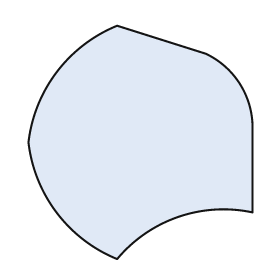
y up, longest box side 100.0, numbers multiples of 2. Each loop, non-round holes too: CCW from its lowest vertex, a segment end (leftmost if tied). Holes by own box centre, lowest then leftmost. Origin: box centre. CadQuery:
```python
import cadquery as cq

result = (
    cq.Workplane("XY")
    .moveTo(-10.0, -50.0)
    .threePointArc((16.0, -32.0), (48.0, -30.0))
    .lineTo(48.0, 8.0)
    .threePointArc((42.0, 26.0), (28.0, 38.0))
    .lineTo(-10.0, 50.0)
    .threePointArc((-36.0, 30.0), (-48.0, 0.0))
    .threePointArc((-36.0, -30.0), (-10.0, -50.0))
    .close()
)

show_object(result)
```